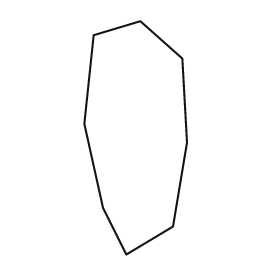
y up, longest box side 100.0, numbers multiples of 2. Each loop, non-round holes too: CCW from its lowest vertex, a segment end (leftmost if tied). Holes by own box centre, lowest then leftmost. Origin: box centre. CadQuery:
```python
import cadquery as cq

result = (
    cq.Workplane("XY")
    .moveTo(-4.0, -50.0)
    .lineTo(16.0, -38.0)
    .lineTo(22.0, -2.0)
    .lineTo(20.0, 34.0)
    .lineTo(2.0, 50.0)
    .lineTo(-18.0, 44.0)
    .lineTo(-22.0, 6.0)
    .lineTo(-14.0, -30.0)
    .close()
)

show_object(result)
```